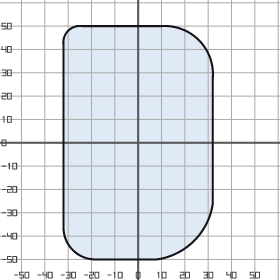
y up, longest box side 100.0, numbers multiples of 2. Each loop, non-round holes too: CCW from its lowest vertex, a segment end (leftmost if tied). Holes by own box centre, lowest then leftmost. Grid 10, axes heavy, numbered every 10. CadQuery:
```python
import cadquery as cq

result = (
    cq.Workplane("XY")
    .moveTo(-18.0, -50.0)
    .lineTo(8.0, -50.0)
    .threePointArc((24.0, -42.0), (32.0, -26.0))
    .lineTo(32.0, 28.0)
    .threePointArc((26.0, 44.0), (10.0, 50.0))
    .lineTo(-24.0, 50.0)
    .threePointArc((-30.0, 48.0), (-32.0, 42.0))
    .lineTo(-32.0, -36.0)
    .threePointArc((-28.0, -46.0), (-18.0, -50.0))
    .close()
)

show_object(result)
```